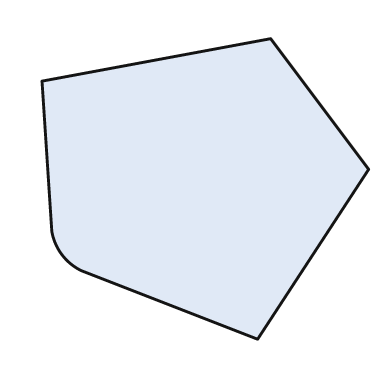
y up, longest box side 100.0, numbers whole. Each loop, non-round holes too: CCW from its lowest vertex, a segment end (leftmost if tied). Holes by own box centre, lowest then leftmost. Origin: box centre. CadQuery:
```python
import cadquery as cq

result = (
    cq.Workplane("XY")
    .moveTo(16.0, -46.0)
    .lineTo(50.0, 6.0)
    .lineTo(20.0, 46.0)
    .lineTo(-50.0, 33.0)
    .lineTo(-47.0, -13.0)
    .threePointArc((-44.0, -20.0), (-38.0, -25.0))
    .close()
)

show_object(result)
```